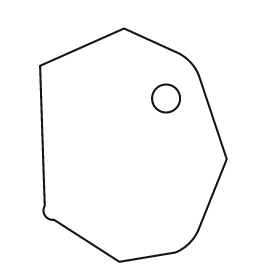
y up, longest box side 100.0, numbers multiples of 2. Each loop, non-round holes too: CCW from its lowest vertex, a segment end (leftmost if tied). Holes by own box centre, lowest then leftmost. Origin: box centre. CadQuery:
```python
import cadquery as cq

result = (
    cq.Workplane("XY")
    .moveTo(-6.0, -50.0)
    .lineTo(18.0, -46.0)
    .threePointArc((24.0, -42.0), (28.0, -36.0))
    .lineTo(40.0, -6.0)
    .lineTo(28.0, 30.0)
    .threePointArc((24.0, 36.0), (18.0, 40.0))
    .lineTo(-4.0, 50.0)
    .lineTo(-40.0, 34.0)
    .lineTo(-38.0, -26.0)
    .threePointArc((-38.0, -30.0), (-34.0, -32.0))
    .close()
    .moveTo(14.0, 20.0)
    .circle(6.0)
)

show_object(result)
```